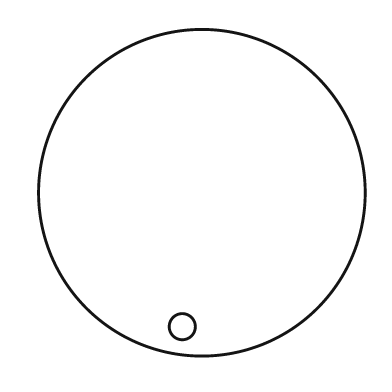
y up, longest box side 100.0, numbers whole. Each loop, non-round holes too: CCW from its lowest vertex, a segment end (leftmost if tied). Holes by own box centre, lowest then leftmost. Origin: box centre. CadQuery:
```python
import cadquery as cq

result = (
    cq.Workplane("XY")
    .moveTo(0.0, 0.0)
    .circle(50.0)
    .moveTo(-6.0, -41.0)
    .circle(4.0)
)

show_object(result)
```